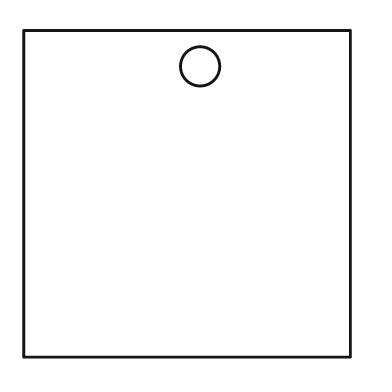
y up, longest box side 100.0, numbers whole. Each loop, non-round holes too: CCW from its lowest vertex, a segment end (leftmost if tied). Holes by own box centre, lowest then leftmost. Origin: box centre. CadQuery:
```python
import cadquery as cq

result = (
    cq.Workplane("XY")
    .moveTo(-50.0, -50.0)
    .lineTo(50.0, -50.0)
    .lineTo(50.0, 50.0)
    .lineTo(-50.0, 50.0)
    .close()
    .moveTo(4.0, 39.0)
    .circle(6.0)
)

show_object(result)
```